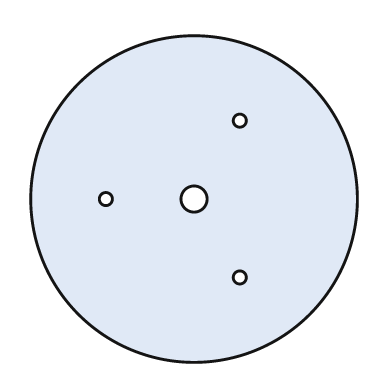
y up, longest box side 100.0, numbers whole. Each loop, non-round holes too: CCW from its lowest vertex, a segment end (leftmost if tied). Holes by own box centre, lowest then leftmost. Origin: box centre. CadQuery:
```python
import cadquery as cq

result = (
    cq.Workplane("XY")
    .moveTo(0.0, 0.0)
    .circle(50.0)
    .moveTo(14.0, -24.0)
    .circle(2.0)
    .moveTo(-27.0, 0.0)
    .circle(2.0)
    .moveTo(0.0, 0.0)
    .circle(4.0)
    .moveTo(14.0, 24.0)
    .circle(2.0)
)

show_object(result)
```